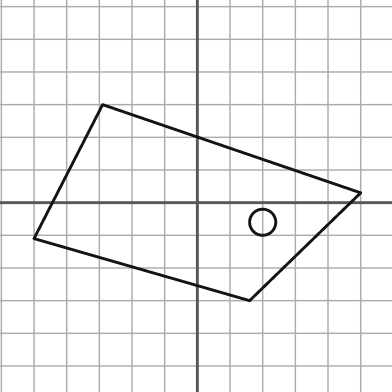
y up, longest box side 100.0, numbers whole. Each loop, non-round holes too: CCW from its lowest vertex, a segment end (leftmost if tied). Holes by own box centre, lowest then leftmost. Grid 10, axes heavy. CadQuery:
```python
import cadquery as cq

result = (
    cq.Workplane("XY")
    .moveTo(16.0, -30.0)
    .lineTo(50.0, 3.0)
    .lineTo(-29.0, 30.0)
    .lineTo(-50.0, -11.0)
    .close()
    .moveTo(20.0, -6.0)
    .circle(4.0)
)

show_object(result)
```